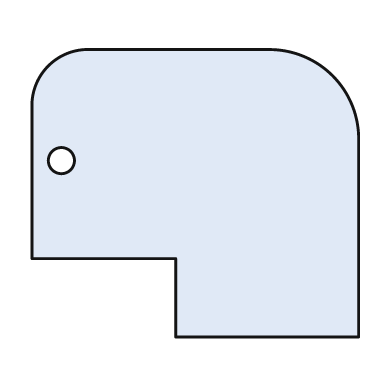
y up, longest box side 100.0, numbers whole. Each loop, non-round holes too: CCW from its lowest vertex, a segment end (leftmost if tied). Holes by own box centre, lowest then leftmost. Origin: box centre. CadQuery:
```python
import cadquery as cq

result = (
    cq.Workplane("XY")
    .moveTo(-6.0, -44.0)
    .lineTo(50.0, -44.0)
    .lineTo(50.0, 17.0)
    .threePointArc((42.0, 36.0), (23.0, 44.0))
    .lineTo(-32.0, 44.0)
    .threePointArc((-45.0, 39.0), (-50.0, 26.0))
    .lineTo(-50.0, -20.0)
    .lineTo(-6.0, -20.0)
    .close()
    .moveTo(-41.0, 10.0)
    .circle(4.0)
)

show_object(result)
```